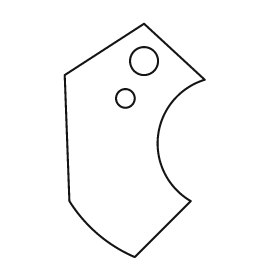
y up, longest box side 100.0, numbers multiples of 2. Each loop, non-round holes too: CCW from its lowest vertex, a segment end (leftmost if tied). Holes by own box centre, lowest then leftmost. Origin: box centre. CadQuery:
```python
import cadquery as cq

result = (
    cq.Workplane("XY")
    .moveTo(0.0, -50.0)
    .lineTo(24.0, -26.0)
    .threePointArc((10.0, 2.0), (30.0, 26.0))
    .lineTo(4.0, 50.0)
    .lineTo(-30.0, 28.0)
    .lineTo(-28.0, -26.0)
    .threePointArc((-16.0, -40.0), (0.0, -50.0))
    .close()
    .moveTo(-4.0, 18.0)
    .circle(4.0)
    .moveTo(4.0, 34.0)
    .circle(6.0)
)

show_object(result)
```